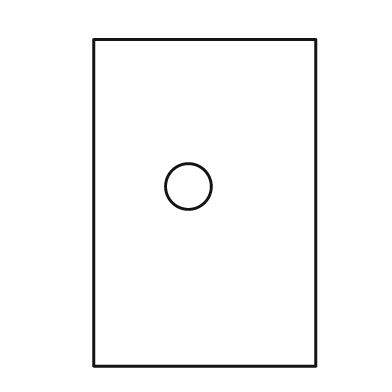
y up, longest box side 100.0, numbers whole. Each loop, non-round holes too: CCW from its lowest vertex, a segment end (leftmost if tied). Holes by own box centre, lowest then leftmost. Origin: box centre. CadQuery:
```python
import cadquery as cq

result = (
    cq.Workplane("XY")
    .moveTo(-34.0, -50.0)
    .lineTo(34.0, -50.0)
    .lineTo(34.0, 50.0)
    .lineTo(-34.0, 50.0)
    .close()
    .moveTo(-5.0, 5.0)
    .circle(7.0)
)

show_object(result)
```